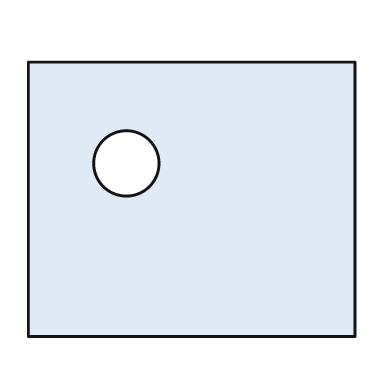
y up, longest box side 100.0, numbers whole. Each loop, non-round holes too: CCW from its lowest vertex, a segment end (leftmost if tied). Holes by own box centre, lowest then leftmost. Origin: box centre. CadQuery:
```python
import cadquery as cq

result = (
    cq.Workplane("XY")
    .moveTo(-50.0, -42.0)
    .lineTo(50.0, -42.0)
    .lineTo(50.0, 42.0)
    .lineTo(-50.0, 42.0)
    .close()
    .moveTo(-20.0, 11.0)
    .circle(10.0)
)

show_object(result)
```